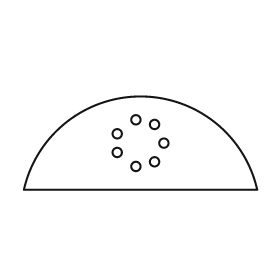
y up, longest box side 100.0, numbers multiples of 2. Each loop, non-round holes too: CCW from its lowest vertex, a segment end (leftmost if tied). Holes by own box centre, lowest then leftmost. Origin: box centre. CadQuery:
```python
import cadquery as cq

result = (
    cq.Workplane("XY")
    .moveTo(-50.0, -20.0)
    .lineTo(50.0, -20.0)
    .threePointArc((0.0, 20.0), (-50.0, -20.0))
    .close()
    .moveTo(-2.0, -10.0)
    .circle(2.0)
    .moveTo(6.0, -8.0)
    .circle(2.0)
    .moveTo(-10.0, -4.0)
    .circle(2.0)
    .moveTo(10.0, 0.0)
    .circle(2.0)
    .moveTo(-10.0, 4.0)
    .circle(2.0)
    .moveTo(6.0, 8.0)
    .circle(2.0)
    .moveTo(-2.0, 10.0)
    .circle(2.0)
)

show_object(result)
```